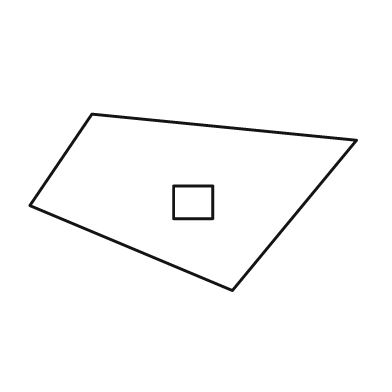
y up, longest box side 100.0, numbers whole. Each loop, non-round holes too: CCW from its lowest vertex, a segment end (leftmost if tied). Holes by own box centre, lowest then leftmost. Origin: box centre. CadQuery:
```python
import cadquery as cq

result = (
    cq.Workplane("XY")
    .moveTo(12.0, -27.0)
    .lineTo(50.0, 19.0)
    .lineTo(-31.0, 27.0)
    .lineTo(-50.0, -1.0)
    .close()
    .moveTo(-6.0, -5.0)
    .lineTo(6.0, -5.0)
    .lineTo(6.0, 5.0)
    .lineTo(-6.0, 5.0)
    .close()
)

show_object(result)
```